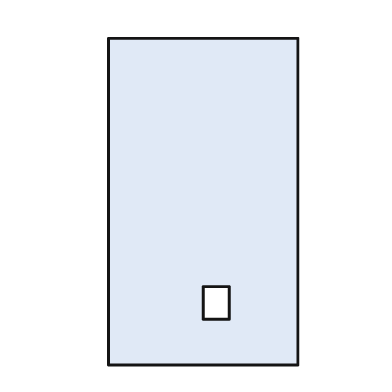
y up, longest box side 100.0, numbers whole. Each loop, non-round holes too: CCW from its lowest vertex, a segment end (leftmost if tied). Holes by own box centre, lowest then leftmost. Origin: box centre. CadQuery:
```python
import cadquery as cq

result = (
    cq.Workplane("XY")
    .moveTo(-29.0, -50.0)
    .lineTo(29.0, -50.0)
    .lineTo(29.0, 50.0)
    .lineTo(-29.0, 50.0)
    .close()
    .moveTo(0.0, -36.0)
    .lineTo(8.0, -36.0)
    .lineTo(8.0, -26.0)
    .lineTo(0.0, -26.0)
    .close()
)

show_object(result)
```